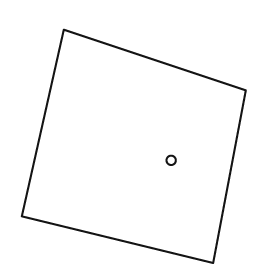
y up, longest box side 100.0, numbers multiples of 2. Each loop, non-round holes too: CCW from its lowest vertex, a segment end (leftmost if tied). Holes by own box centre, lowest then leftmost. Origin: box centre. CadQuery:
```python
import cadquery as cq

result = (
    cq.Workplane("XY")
    .moveTo(34.0, -50.0)
    .lineTo(48.0, 24.0)
    .lineTo(-30.0, 50.0)
    .lineTo(-48.0, -30.0)
    .close()
    .moveTo(16.0, -6.0)
    .circle(2.0)
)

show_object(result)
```